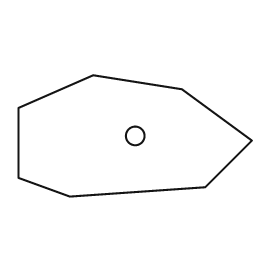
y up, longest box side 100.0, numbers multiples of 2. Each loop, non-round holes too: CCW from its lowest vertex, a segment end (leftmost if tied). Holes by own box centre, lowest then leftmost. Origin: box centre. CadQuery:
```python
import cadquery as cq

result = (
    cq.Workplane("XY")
    .moveTo(-28.0, -26.0)
    .lineTo(30.0, -22.0)
    .lineTo(50.0, -2.0)
    .lineTo(20.0, 20.0)
    .lineTo(-18.0, 26.0)
    .lineTo(-50.0, 12.0)
    .lineTo(-50.0, -18.0)
    .close()
    .moveTo(0.0, 0.0)
    .circle(4.0)
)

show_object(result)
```